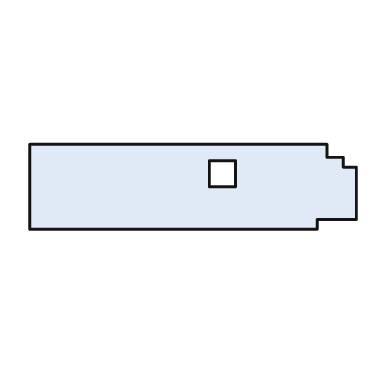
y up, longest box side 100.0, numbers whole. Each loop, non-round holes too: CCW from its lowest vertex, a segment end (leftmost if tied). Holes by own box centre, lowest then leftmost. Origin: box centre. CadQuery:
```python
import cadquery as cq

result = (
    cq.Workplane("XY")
    .moveTo(-50.0, -13.0)
    .lineTo(38.0, -13.0)
    .lineTo(38.0, -10.0)
    .lineTo(50.0, -10.0)
    .lineTo(50.0, 6.0)
    .lineTo(46.0, 6.0)
    .lineTo(46.0, 9.0)
    .lineTo(41.0, 9.0)
    .lineTo(41.0, 13.0)
    .lineTo(-50.0, 13.0)
    .close()
    .moveTo(5.0, 0.0)
    .lineTo(13.0, 0.0)
    .lineTo(13.0, 8.0)
    .lineTo(5.0, 8.0)
    .close()
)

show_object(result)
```